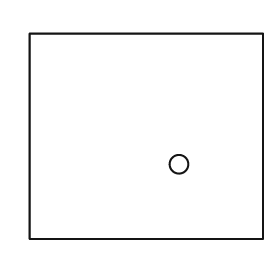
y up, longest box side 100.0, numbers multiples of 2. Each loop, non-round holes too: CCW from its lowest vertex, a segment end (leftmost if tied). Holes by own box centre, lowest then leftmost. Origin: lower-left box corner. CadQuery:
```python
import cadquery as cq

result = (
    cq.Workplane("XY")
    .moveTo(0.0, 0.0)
    .lineTo(100.0, 0.0)
    .lineTo(100.0, 88.0)
    .lineTo(0.0, 88.0)
    .close()
    .moveTo(64.0, 32.0)
    .circle(4.0)
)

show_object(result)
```